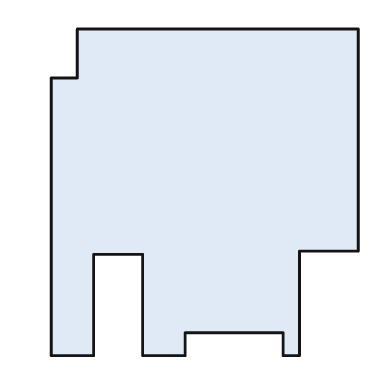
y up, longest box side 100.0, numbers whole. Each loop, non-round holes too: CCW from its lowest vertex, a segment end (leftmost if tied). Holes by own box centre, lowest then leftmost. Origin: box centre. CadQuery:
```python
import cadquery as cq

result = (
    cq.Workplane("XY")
    .moveTo(-47.0, -50.0)
    .lineTo(-34.0, -50.0)
    .lineTo(-34.0, -19.0)
    .lineTo(-19.0, -19.0)
    .lineTo(-19.0, -50.0)
    .lineTo(-6.0, -50.0)
    .lineTo(-6.0, -43.0)
    .lineTo(24.0, -43.0)
    .lineTo(24.0, -50.0)
    .lineTo(29.0, -50.0)
    .lineTo(29.0, -18.0)
    .lineTo(47.0, -18.0)
    .lineTo(47.0, 50.0)
    .lineTo(-39.0, 50.0)
    .lineTo(-39.0, 35.0)
    .lineTo(-47.0, 35.0)
    .close()
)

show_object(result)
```